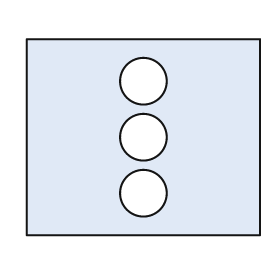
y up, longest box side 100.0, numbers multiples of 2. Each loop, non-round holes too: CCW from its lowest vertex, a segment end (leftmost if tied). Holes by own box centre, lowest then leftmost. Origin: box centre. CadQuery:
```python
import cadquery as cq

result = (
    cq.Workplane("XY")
    .moveTo(-50.0, -42.0)
    .lineTo(50.0, -42.0)
    .lineTo(50.0, 42.0)
    .lineTo(-50.0, 42.0)
    .close()
    .moveTo(0.0, -24.0)
    .circle(10.0)
    .moveTo(0.0, 0.0)
    .circle(10.0)
    .moveTo(0.0, 24.0)
    .circle(10.0)
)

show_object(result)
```